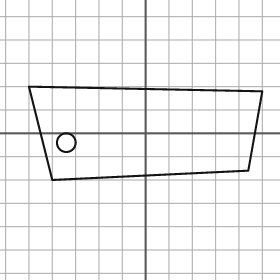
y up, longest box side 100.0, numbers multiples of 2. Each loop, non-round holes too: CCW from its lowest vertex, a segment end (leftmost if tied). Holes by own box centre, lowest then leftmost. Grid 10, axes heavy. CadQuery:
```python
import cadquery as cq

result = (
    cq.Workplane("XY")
    .moveTo(-40.0, -20.0)
    .lineTo(44.0, -16.0)
    .lineTo(50.0, 18.0)
    .lineTo(-50.0, 20.0)
    .close()
    .moveTo(-34.0, -4.0)
    .circle(4.0)
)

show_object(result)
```